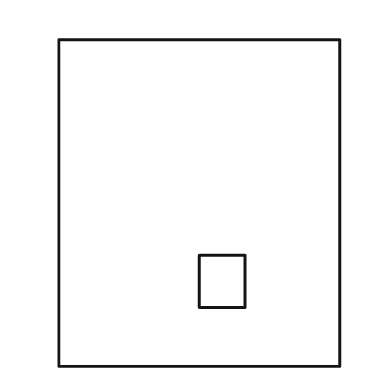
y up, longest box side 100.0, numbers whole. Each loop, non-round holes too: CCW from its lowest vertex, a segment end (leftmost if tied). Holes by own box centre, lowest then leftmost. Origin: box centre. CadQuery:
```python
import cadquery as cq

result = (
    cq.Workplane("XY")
    .moveTo(-43.0, -50.0)
    .lineTo(43.0, -50.0)
    .lineTo(43.0, 50.0)
    .lineTo(-43.0, 50.0)
    .close()
    .moveTo(0.0, -32.0)
    .lineTo(14.0, -32.0)
    .lineTo(14.0, -16.0)
    .lineTo(0.0, -16.0)
    .close()
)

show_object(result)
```